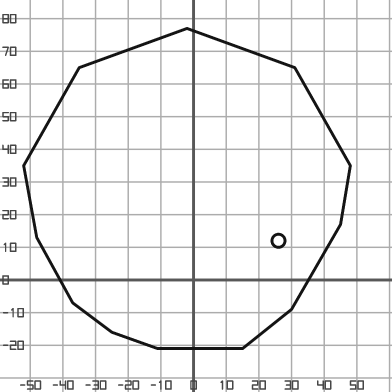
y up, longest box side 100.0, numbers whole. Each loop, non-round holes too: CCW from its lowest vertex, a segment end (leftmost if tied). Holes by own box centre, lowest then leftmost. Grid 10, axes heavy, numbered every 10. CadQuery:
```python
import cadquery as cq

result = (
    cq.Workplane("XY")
    .moveTo(-11.0, -21.0)
    .lineTo(15.0, -21.0)
    .lineTo(30.0, -9.0)
    .lineTo(45.0, 17.0)
    .lineTo(48.0, 35.0)
    .lineTo(31.0, 65.0)
    .lineTo(-2.0, 77.0)
    .lineTo(-35.0, 65.0)
    .lineTo(-52.0, 35.0)
    .lineTo(-48.0, 13.0)
    .lineTo(-37.0, -7.0)
    .lineTo(-25.0, -16.0)
    .close()
    .moveTo(26.0, 12.0)
    .circle(2.0)
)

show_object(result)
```